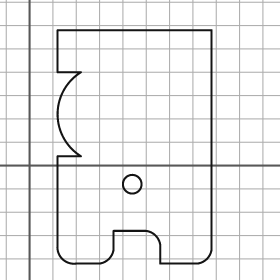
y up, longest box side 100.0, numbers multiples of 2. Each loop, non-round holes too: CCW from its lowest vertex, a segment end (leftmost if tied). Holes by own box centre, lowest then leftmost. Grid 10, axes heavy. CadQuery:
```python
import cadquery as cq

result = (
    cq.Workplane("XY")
    .moveTo(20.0, -42.0)
    .lineTo(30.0, -42.0)
    .threePointArc((34.0, -40.0), (36.0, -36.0))
    .lineTo(36.0, -28.0)
    .lineTo(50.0, -28.0)
    .threePointArc((54.0, -30.0), (56.0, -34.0))
    .lineTo(56.0, -42.0)
    .lineTo(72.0, -42.0)
    .threePointArc((76.0, -40.0), (78.0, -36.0))
    .lineTo(78.0, 58.0)
    .lineTo(12.0, 58.0)
    .lineTo(12.0, 40.0)
    .lineTo(22.0, 40.0)
    .threePointArc((12.0, 22.0), (22.0, 4.0))
    .lineTo(12.0, 4.0)
    .lineTo(12.0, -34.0)
    .threePointArc((14.0, -40.0), (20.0, -42.0))
    .close()
    .moveTo(44.0, -8.0)
    .circle(4.0)
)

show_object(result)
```